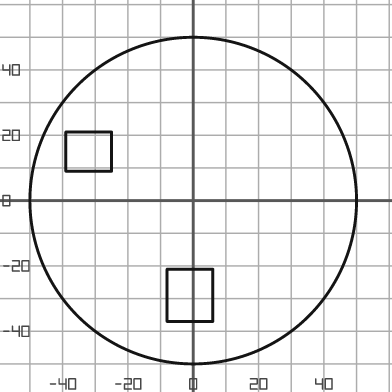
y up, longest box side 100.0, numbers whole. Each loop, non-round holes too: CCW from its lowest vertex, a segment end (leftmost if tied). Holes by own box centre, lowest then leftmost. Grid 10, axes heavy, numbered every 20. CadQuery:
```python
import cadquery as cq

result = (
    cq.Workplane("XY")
    .moveTo(0.0, 0.0)
    .circle(50.0)
    .moveTo(-8.0, -37.0)
    .lineTo(6.0, -37.0)
    .lineTo(6.0, -21.0)
    .lineTo(-8.0, -21.0)
    .close()
    .moveTo(-39.0, 9.0)
    .lineTo(-25.0, 9.0)
    .lineTo(-25.0, 21.0)
    .lineTo(-39.0, 21.0)
    .close()
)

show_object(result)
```